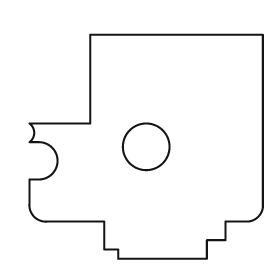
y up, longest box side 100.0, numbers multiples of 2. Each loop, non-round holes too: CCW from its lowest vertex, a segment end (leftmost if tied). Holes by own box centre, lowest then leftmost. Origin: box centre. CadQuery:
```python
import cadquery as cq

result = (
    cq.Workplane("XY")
    .moveTo(-12.0, -48.0)
    .lineTo(26.0, -48.0)
    .lineTo(26.0, -40.0)
    .lineTo(34.0, -40.0)
    .lineTo(34.0, -32.0)
    .lineTo(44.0, -32.0)
    .threePointArc((48.0, -30.0), (50.0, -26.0))
    .lineTo(50.0, 48.0)
    .lineTo(-24.0, 48.0)
    .lineTo(-24.0, 10.0)
    .lineTo(-50.0, 10.0)
    .threePointArc((-48.0, 6.0), (-50.0, 2.0))
    .lineTo(-46.0, 2.0)
    .threePointArc((-38.0, -6.0), (-46.0, -14.0))
    .lineTo(-50.0, -14.0)
    .lineTo(-50.0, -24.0)
    .threePointArc((-48.0, -30.0), (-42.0, -32.0))
    .lineTo(-18.0, -32.0)
    .lineTo(-18.0, -44.0)
    .lineTo(-12.0, -44.0)
    .close()
    .moveTo(0.0, 0.0)
    .circle(10.0)
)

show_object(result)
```